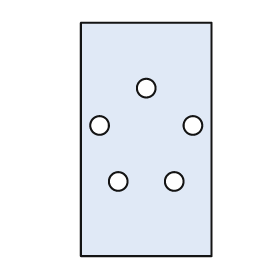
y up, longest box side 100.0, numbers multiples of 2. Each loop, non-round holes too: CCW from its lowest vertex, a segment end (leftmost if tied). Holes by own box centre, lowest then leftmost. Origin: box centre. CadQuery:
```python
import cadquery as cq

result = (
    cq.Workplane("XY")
    .moveTo(-28.0, -50.0)
    .lineTo(28.0, -50.0)
    .lineTo(28.0, 50.0)
    .lineTo(-28.0, 50.0)
    .close()
    .moveTo(-12.0, -18.0)
    .circle(4.0)
    .moveTo(12.0, -18.0)
    .circle(4.0)
    .moveTo(-20.0, 6.0)
    .circle(4.0)
    .moveTo(20.0, 6.0)
    .circle(4.0)
    .moveTo(0.0, 22.0)
    .circle(4.0)
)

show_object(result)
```